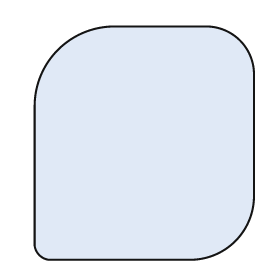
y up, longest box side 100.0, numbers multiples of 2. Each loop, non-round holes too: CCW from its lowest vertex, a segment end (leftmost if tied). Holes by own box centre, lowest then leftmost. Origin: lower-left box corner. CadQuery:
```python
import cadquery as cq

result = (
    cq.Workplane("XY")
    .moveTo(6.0, 0.0)
    .lineTo(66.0, 0.0)
    .threePointArc((86.0, 8.0), (94.0, 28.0))
    .lineTo(94.0, 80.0)
    .threePointArc((88.0, 94.0), (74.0, 100.0))
    .lineTo(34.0, 100.0)
    .threePointArc((10.0, 90.0), (0.0, 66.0))
    .lineTo(0.0, 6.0)
    .threePointArc((2.0, 2.0), (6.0, 0.0))
    .close()
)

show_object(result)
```